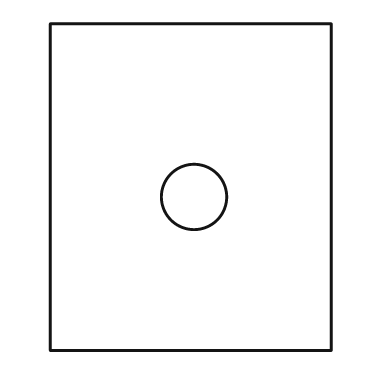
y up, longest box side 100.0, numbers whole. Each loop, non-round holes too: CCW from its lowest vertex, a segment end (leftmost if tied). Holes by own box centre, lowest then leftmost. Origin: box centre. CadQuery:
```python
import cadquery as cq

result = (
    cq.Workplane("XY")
    .moveTo(-43.0, -50.0)
    .lineTo(43.0, -50.0)
    .lineTo(43.0, 50.0)
    .lineTo(-43.0, 50.0)
    .close()
    .moveTo(1.0, -3.0)
    .circle(10.0)
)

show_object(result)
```